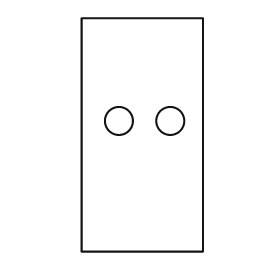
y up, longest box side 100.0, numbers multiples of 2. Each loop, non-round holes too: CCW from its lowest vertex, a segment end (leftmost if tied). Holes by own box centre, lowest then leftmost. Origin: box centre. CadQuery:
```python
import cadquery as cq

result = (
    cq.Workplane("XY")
    .moveTo(-26.0, -50.0)
    .lineTo(26.0, -50.0)
    .lineTo(26.0, 50.0)
    .lineTo(-26.0, 50.0)
    .close()
    .moveTo(-10.0, 6.0)
    .circle(6.0)
    .moveTo(12.0, 6.0)
    .circle(6.0)
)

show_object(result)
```